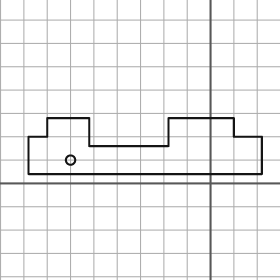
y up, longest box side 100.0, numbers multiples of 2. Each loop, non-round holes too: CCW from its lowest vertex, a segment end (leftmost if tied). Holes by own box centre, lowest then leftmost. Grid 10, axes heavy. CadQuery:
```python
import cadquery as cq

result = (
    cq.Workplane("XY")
    .moveTo(-78.0, 4.0)
    .lineTo(22.0, 4.0)
    .lineTo(22.0, 20.0)
    .lineTo(10.0, 20.0)
    .lineTo(10.0, 28.0)
    .lineTo(-18.0, 28.0)
    .lineTo(-18.0, 16.0)
    .lineTo(-52.0, 16.0)
    .lineTo(-52.0, 28.0)
    .lineTo(-70.0, 28.0)
    .lineTo(-70.0, 20.0)
    .lineTo(-78.0, 20.0)
    .close()
    .moveTo(-60.0, 10.0)
    .circle(2.0)
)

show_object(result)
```